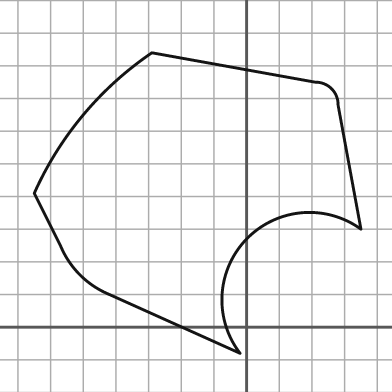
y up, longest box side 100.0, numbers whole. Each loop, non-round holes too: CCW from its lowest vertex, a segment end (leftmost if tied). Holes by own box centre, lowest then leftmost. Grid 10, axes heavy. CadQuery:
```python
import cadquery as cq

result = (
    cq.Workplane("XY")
    .moveTo(-2.0, -8.0)
    .threePointArc((0.0, 27.0), (35.0, 30.0))
    .lineTo(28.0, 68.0)
    .threePointArc((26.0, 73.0), (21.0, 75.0))
    .lineTo(-29.0, 84.0)
    .threePointArc((-50.0, 65.0), (-65.0, 41.0))
    .lineTo(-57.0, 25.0)
    .threePointArc((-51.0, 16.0), (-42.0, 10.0))
    .close()
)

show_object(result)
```